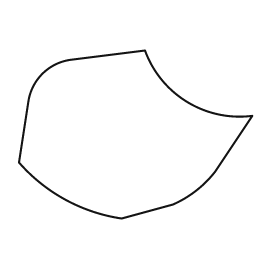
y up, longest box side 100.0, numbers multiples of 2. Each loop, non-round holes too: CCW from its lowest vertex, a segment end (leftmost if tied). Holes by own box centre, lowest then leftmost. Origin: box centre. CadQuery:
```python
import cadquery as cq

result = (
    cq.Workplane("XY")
    .moveTo(-6.0, -36.0)
    .lineTo(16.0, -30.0)
    .threePointArc((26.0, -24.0), (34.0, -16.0))
    .lineTo(50.0, 8.0)
    .threePointArc((22.0, 14.0), (4.0, 36.0))
    .lineTo(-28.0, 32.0)
    .threePointArc((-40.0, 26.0), (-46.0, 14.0))
    .lineTo(-50.0, -12.0)
    .threePointArc((-30.0, -28.0), (-6.0, -36.0))
    .close()
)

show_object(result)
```